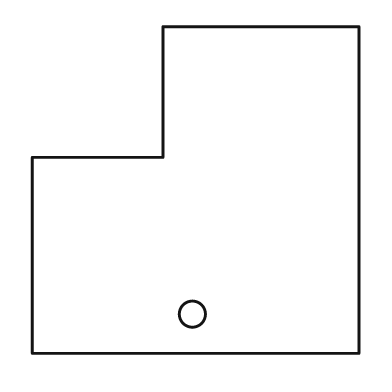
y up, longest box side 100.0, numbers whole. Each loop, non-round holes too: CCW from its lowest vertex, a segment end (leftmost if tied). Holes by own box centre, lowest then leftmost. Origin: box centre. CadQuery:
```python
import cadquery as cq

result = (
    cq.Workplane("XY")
    .moveTo(-50.0, -50.0)
    .lineTo(50.0, -50.0)
    .lineTo(50.0, 50.0)
    .lineTo(-10.0, 50.0)
    .lineTo(-10.0, 10.0)
    .lineTo(-50.0, 10.0)
    .close()
    .moveTo(-1.0, -38.0)
    .circle(4.0)
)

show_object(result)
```